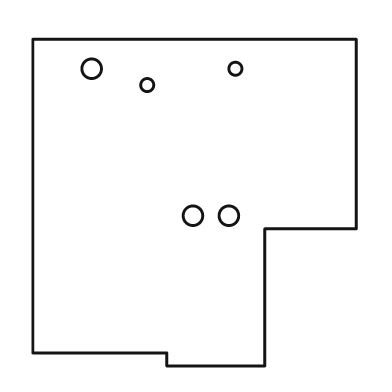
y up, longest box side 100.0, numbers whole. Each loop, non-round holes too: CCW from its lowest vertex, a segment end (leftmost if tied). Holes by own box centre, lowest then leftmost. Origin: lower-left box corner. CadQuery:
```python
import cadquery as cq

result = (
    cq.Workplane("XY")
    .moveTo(41.0, 0.0)
    .lineTo(71.0, 0.0)
    .lineTo(71.0, 42.0)
    .lineTo(99.0, 42.0)
    .lineTo(99.0, 100.0)
    .lineTo(0.0, 100.0)
    .lineTo(0.0, 4.0)
    .lineTo(41.0, 4.0)
    .close()
    .moveTo(49.0, 46.0)
    .circle(3.0)
    .moveTo(60.0, 46.0)
    .circle(3.0)
    .moveTo(35.0, 86.0)
    .circle(2.0)
    .moveTo(18.0, 91.0)
    .circle(3.0)
    .moveTo(62.0, 91.0)
    .circle(2.0)
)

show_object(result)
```